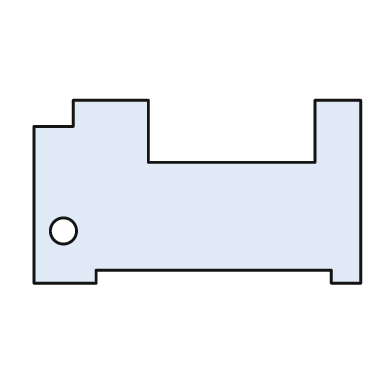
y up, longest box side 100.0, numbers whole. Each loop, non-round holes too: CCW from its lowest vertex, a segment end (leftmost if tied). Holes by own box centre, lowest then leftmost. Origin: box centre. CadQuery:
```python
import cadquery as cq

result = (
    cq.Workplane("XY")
    .moveTo(-50.0, -28.0)
    .lineTo(-31.0, -28.0)
    .lineTo(-31.0, -24.0)
    .lineTo(41.0, -24.0)
    .lineTo(41.0, -28.0)
    .lineTo(50.0, -28.0)
    .lineTo(50.0, 28.0)
    .lineTo(36.0, 28.0)
    .lineTo(36.0, 9.0)
    .lineTo(-15.0, 9.0)
    .lineTo(-15.0, 28.0)
    .lineTo(-38.0, 28.0)
    .lineTo(-38.0, 20.0)
    .lineTo(-50.0, 20.0)
    .close()
    .moveTo(-41.0, -12.0)
    .circle(4.0)
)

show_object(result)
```